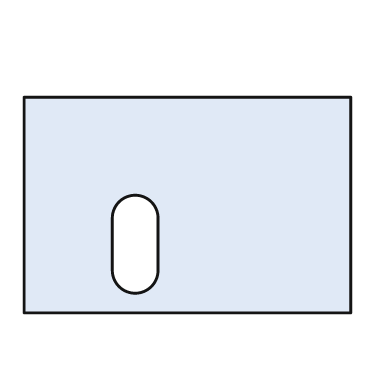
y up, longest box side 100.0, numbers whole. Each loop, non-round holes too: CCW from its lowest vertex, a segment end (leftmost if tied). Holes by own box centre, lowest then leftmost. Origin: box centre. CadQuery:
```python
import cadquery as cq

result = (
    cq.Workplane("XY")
    .moveTo(-50.0, -33.0)
    .lineTo(50.0, -33.0)
    .lineTo(50.0, 33.0)
    .lineTo(-50.0, 33.0)
    .close()
    .moveTo(-23.0, -20.0)
    .threePointArc((-16.0, -27.0), (-9.0, -20.0))
    .lineTo(-9.0, -4.0)
    .threePointArc((-16.0, 3.0), (-23.0, -4.0))
    .close()
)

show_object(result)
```